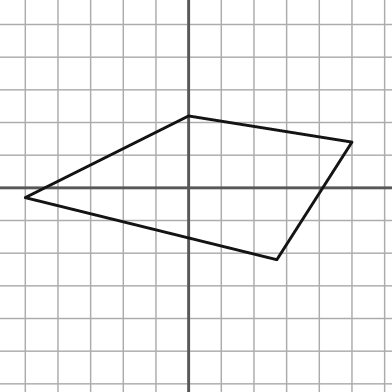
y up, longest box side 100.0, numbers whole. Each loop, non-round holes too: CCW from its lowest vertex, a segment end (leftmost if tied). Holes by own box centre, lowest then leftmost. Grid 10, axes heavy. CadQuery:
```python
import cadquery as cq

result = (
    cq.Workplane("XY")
    .moveTo(27.0, -22.0)
    .lineTo(50.0, 14.0)
    .lineTo(0.0, 22.0)
    .lineTo(-50.0, -3.0)
    .close()
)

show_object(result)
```